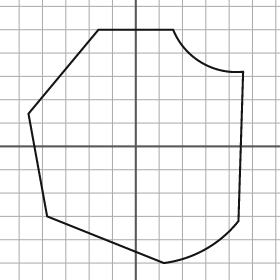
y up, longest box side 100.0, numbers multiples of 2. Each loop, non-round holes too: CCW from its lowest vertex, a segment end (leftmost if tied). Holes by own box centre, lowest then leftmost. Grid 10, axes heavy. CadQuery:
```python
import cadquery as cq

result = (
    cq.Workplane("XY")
    .moveTo(12.0, -50.0)
    .threePointArc((30.0, -44.0), (44.0, -32.0))
    .lineTo(46.0, 32.0)
    .threePointArc((28.0, 36.0), (16.0, 50.0))
    .lineTo(-16.0, 50.0)
    .lineTo(-46.0, 14.0)
    .lineTo(-38.0, -30.0)
    .close()
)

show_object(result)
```